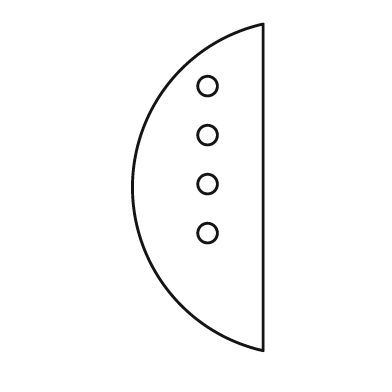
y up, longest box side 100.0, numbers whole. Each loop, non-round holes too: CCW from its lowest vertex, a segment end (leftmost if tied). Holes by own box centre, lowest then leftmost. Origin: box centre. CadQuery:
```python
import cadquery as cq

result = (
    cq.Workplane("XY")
    .moveTo(20.0, -50.0)
    .lineTo(20.0, 50.0)
    .threePointArc((-20.0, 0.0), (20.0, -50.0))
    .close()
    .moveTo(3.0, -14.0)
    .circle(3.0)
    .moveTo(3.0, 1.0)
    .circle(3.0)
    .moveTo(3.0, 16.0)
    .circle(3.0)
    .moveTo(3.0, 31.0)
    .circle(3.0)
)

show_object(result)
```